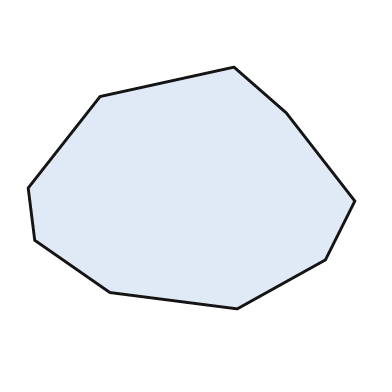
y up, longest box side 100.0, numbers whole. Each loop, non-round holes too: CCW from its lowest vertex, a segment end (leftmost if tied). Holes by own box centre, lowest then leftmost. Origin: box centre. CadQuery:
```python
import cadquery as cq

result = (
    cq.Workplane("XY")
    .moveTo(14.0, -37.0)
    .lineTo(41.0, -22.0)
    .lineTo(50.0, -4.0)
    .lineTo(29.0, 23.0)
    .lineTo(13.0, 37.0)
    .lineTo(-28.0, 28.0)
    .lineTo(-50.0, 0.0)
    .lineTo(-48.0, -16.0)
    .lineTo(-25.0, -32.0)
    .close()
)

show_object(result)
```